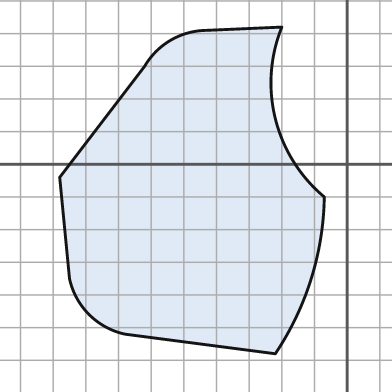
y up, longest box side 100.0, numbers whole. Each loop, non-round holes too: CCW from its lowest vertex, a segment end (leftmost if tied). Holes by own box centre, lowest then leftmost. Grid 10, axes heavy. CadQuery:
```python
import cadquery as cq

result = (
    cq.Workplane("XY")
    .moveTo(-22.0, -58.0)
    .threePointArc((-11.0, -35.0), (-7.0, -10.0))
    .threePointArc((-22.0, 14.0), (-20.0, 42.0))
    .lineTo(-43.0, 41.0)
    .threePointArc((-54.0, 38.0), (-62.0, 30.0))
    .lineTo(-88.0, -4.0)
    .lineTo(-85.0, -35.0)
    .threePointArc((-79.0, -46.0), (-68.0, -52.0))
    .close()
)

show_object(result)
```